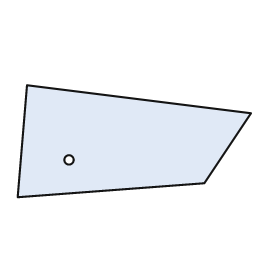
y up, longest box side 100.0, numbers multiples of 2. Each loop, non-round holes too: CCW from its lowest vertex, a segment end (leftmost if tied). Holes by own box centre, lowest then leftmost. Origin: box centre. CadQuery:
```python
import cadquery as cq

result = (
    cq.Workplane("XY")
    .moveTo(-50.0, -24.0)
    .lineTo(30.0, -18.0)
    .lineTo(50.0, 12.0)
    .lineTo(-46.0, 24.0)
    .close()
    .moveTo(-28.0, -8.0)
    .circle(2.0)
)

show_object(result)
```